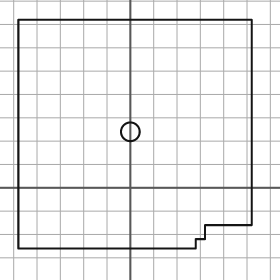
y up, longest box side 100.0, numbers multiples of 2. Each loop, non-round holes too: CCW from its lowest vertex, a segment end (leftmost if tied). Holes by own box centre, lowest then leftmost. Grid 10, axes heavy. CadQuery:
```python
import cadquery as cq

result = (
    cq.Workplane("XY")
    .moveTo(-48.0, -26.0)
    .lineTo(28.0, -26.0)
    .lineTo(28.0, -22.0)
    .lineTo(32.0, -22.0)
    .lineTo(32.0, -16.0)
    .lineTo(52.0, -16.0)
    .lineTo(52.0, 72.0)
    .lineTo(-48.0, 72.0)
    .close()
    .moveTo(0.0, 24.0)
    .circle(4.0)
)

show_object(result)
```